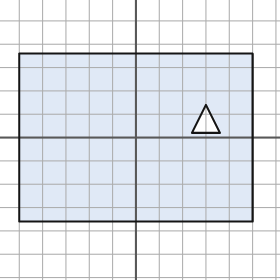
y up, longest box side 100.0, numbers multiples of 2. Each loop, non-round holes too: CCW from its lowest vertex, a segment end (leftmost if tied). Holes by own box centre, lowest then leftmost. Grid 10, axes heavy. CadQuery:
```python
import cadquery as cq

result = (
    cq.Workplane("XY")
    .moveTo(-50.0, -36.0)
    .lineTo(50.0, -36.0)
    .lineTo(50.0, 36.0)
    .lineTo(-50.0, 36.0)
    .close()
    .moveTo(24.0, 2.0)
    .lineTo(36.0, 2.0)
    .lineTo(30.0, 14.0)
    .close()
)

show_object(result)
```